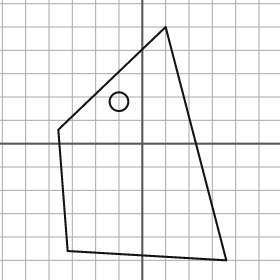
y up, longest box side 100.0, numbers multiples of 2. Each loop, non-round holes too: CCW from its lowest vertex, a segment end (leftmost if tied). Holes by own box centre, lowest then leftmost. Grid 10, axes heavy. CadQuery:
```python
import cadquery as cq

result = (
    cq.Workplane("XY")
    .moveTo(36.0, -50.0)
    .lineTo(10.0, 50.0)
    .lineTo(-36.0, 6.0)
    .lineTo(-32.0, -46.0)
    .close()
    .moveTo(-10.0, 18.0)
    .circle(4.0)
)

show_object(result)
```